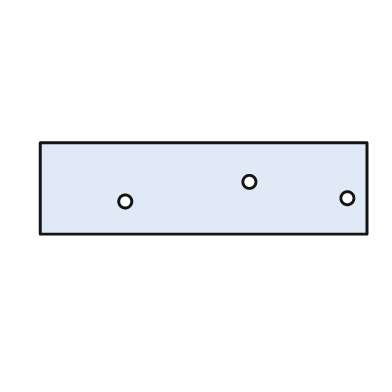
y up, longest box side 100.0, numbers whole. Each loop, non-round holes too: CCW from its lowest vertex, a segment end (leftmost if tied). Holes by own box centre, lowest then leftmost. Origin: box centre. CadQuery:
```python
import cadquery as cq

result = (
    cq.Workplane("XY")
    .moveTo(-50.0, -14.0)
    .lineTo(50.0, -14.0)
    .lineTo(50.0, 14.0)
    .lineTo(-50.0, 14.0)
    .close()
    .moveTo(-24.0, -4.0)
    .circle(2.0)
    .moveTo(44.0, -3.0)
    .circle(2.0)
    .moveTo(14.0, 2.0)
    .circle(2.0)
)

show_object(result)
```